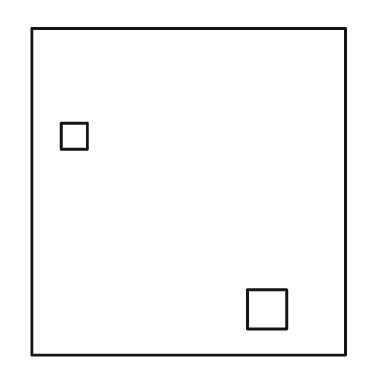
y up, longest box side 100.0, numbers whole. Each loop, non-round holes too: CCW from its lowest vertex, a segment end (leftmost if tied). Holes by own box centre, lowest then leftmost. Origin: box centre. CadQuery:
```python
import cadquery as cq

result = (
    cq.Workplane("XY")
    .moveTo(-48.0, -50.0)
    .lineTo(48.0, -50.0)
    .lineTo(48.0, 50.0)
    .lineTo(-48.0, 50.0)
    .close()
    .moveTo(18.0, -42.0)
    .lineTo(30.0, -42.0)
    .lineTo(30.0, -30.0)
    .lineTo(18.0, -30.0)
    .close()
    .moveTo(-39.0, 13.0)
    .lineTo(-31.0, 13.0)
    .lineTo(-31.0, 21.0)
    .lineTo(-39.0, 21.0)
    .close()
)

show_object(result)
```